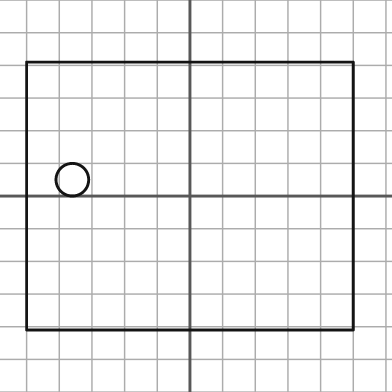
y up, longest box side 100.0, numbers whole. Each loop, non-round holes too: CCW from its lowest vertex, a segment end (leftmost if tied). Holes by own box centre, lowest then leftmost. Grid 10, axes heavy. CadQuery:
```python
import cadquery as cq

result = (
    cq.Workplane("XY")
    .moveTo(-50.0, -41.0)
    .lineTo(50.0, -41.0)
    .lineTo(50.0, 41.0)
    .lineTo(-50.0, 41.0)
    .close()
    .moveTo(-36.0, 5.0)
    .circle(5.0)
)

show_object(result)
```